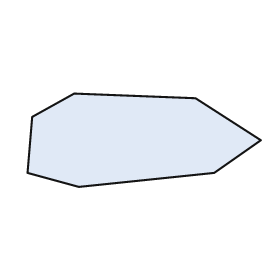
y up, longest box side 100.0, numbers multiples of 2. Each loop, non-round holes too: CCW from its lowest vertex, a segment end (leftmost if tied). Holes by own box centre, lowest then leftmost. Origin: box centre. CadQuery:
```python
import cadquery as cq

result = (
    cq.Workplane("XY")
    .moveTo(-28.0, -20.0)
    .lineTo(30.0, -14.0)
    .lineTo(50.0, 0.0)
    .lineTo(22.0, 18.0)
    .lineTo(-30.0, 20.0)
    .lineTo(-48.0, 10.0)
    .lineTo(-50.0, -14.0)
    .close()
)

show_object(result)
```